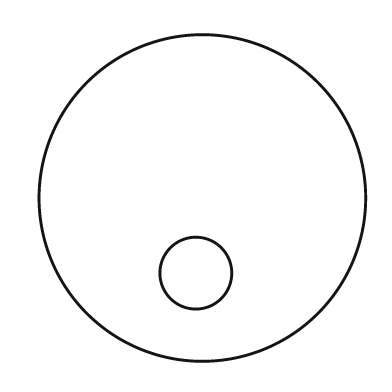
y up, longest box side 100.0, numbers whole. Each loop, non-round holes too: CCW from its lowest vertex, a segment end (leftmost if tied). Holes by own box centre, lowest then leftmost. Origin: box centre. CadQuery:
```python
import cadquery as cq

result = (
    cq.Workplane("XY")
    .moveTo(0.0, 0.0)
    .circle(50.0)
    .moveTo(-2.0, -23.0)
    .circle(11.0)
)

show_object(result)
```